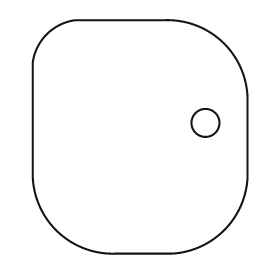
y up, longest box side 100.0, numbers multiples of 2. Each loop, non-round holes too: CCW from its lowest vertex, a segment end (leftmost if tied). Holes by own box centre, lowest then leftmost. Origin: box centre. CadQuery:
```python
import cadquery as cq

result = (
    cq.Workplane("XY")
    .moveTo(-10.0, -50.0)
    .lineTo(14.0, -50.0)
    .threePointArc((36.0, -40.0), (46.0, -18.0))
    .lineTo(46.0, 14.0)
    .threePointArc((36.0, 40.0), (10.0, 50.0))
    .lineTo(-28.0, 50.0)
    .threePointArc((-40.0, 44.0), (-46.0, 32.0))
    .lineTo(-46.0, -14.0)
    .threePointArc((-36.0, -40.0), (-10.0, -50.0))
    .close()
    .moveTo(28.0, 6.0)
    .circle(6.0)
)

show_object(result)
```